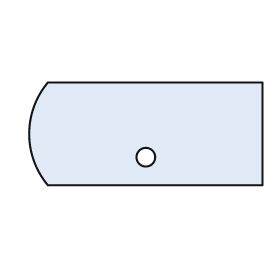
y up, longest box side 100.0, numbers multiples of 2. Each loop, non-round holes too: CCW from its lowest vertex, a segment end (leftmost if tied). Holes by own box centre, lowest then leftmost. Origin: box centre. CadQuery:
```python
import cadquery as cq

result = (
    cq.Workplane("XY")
    .moveTo(-42.0, -22.0)
    .lineTo(50.0, -22.0)
    .lineTo(50.0, 22.0)
    .lineTo(-42.0, 22.0)
    .threePointArc((-50.0, 0.0), (-42.0, -22.0))
    .close()
    .moveTo(0.0, -10.0)
    .circle(4.0)
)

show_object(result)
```